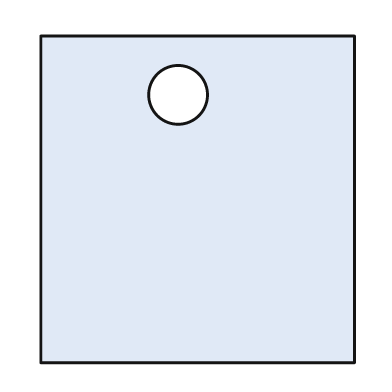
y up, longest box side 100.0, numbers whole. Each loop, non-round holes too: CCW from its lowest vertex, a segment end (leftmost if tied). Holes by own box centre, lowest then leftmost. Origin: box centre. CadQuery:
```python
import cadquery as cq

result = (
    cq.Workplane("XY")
    .moveTo(-48.0, -50.0)
    .lineTo(48.0, -50.0)
    .lineTo(48.0, 50.0)
    .lineTo(-48.0, 50.0)
    .close()
    .moveTo(-6.0, 32.0)
    .circle(9.0)
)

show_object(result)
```